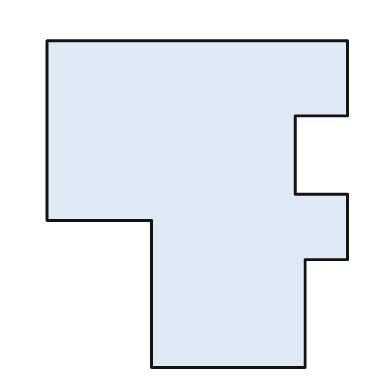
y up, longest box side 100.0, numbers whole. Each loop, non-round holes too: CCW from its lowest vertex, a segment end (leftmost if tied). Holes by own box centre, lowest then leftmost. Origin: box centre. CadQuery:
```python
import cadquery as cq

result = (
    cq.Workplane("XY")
    .moveTo(-14.0, -50.0)
    .lineTo(33.0, -50.0)
    .lineTo(33.0, -17.0)
    .lineTo(46.0, -17.0)
    .lineTo(46.0, 3.0)
    .lineTo(30.0, 3.0)
    .lineTo(30.0, 27.0)
    .lineTo(46.0, 27.0)
    .lineTo(46.0, 50.0)
    .lineTo(-46.0, 50.0)
    .lineTo(-46.0, -5.0)
    .lineTo(-14.0, -5.0)
    .close()
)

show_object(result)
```